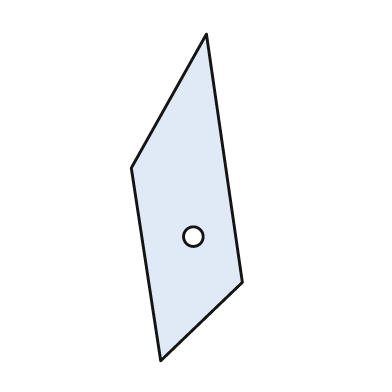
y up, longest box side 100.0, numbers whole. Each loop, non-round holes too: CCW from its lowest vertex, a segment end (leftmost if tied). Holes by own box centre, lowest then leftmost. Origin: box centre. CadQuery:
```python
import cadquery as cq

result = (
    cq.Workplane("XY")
    .moveTo(-8.0, -50.0)
    .lineTo(17.0, -26.0)
    .lineTo(6.0, 50.0)
    .lineTo(-17.0, 9.0)
    .close()
    .moveTo(2.0, -12.0)
    .circle(3.0)
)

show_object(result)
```